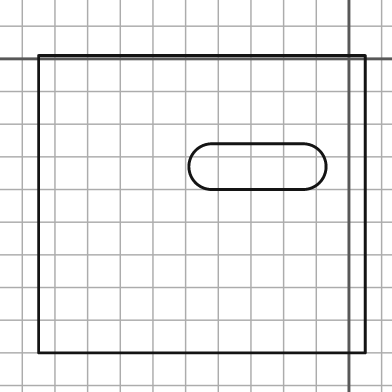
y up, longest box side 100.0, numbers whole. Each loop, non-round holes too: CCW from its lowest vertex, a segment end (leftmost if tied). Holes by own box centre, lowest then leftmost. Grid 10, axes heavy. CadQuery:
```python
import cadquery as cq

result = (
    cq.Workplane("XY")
    .moveTo(-95.0, -90.0)
    .lineTo(5.0, -90.0)
    .lineTo(5.0, 1.0)
    .lineTo(-95.0, 1.0)
    .close()
    .moveTo(-42.0, -40.0)
    .lineTo(-14.0, -40.0)
    .threePointArc((-7.0, -33.0), (-14.0, -26.0))
    .lineTo(-42.0, -26.0)
    .threePointArc((-49.0, -33.0), (-42.0, -40.0))
    .close()
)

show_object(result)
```